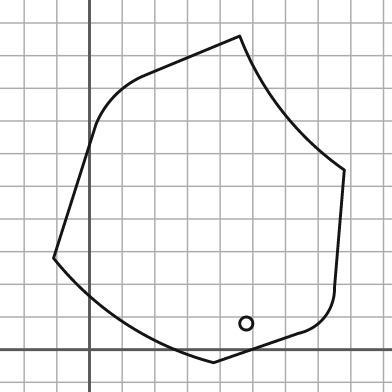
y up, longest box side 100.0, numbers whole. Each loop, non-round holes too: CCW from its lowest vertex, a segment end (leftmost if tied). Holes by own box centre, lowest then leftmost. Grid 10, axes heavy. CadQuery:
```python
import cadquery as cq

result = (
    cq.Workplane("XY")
    .moveTo(38.0, -4.0)
    .lineTo(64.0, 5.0)
    .threePointArc((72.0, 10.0), (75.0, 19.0))
    .lineTo(78.0, 55.0)
    .threePointArc((59.0, 73.0), (46.0, 96.0))
    .lineTo(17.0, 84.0)
    .threePointArc((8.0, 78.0), (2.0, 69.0))
    .lineTo(-11.0, 28.0)
    .threePointArc((11.0, 8.0), (38.0, -4.0))
    .close()
    .moveTo(48.0, 8.0)
    .circle(2.0)
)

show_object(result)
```